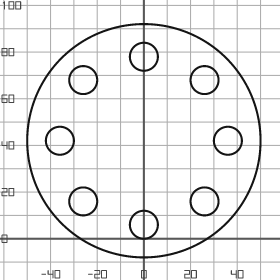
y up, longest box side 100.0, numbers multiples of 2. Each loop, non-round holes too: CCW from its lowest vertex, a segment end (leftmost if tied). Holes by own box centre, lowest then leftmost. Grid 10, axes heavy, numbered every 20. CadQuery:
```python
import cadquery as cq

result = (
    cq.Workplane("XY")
    .moveTo(0.0, 42.0)
    .circle(50.0)
    .moveTo(0.0, 6.0)
    .circle(6.0)
    .moveTo(-26.0, 16.0)
    .circle(6.0)
    .moveTo(26.0, 16.0)
    .circle(6.0)
    .moveTo(-36.0, 42.0)
    .circle(6.0)
    .moveTo(36.0, 42.0)
    .circle(6.0)
    .moveTo(-26.0, 68.0)
    .circle(6.0)
    .moveTo(26.0, 68.0)
    .circle(6.0)
    .moveTo(0.0, 78.0)
    .circle(6.0)
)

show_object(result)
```